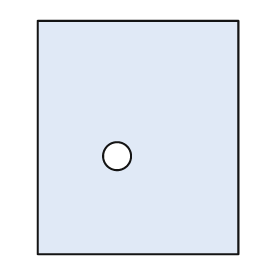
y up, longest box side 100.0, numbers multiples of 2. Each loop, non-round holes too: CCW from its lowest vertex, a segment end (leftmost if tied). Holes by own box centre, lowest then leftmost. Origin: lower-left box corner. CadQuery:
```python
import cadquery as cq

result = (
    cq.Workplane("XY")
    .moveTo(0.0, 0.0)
    .lineTo(86.0, 0.0)
    .lineTo(86.0, 100.0)
    .lineTo(0.0, 100.0)
    .close()
    .moveTo(34.0, 42.0)
    .circle(6.0)
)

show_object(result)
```